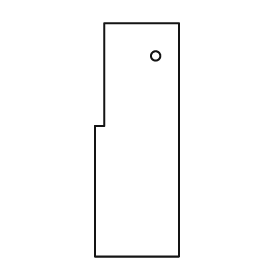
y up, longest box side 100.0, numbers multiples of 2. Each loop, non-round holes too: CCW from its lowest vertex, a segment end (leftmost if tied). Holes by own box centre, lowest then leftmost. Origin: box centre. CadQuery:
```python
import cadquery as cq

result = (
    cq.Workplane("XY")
    .moveTo(-18.0, -50.0)
    .lineTo(18.0, -50.0)
    .lineTo(18.0, 50.0)
    .lineTo(-14.0, 50.0)
    .lineTo(-14.0, 6.0)
    .lineTo(-18.0, 6.0)
    .close()
    .moveTo(8.0, 36.0)
    .circle(2.0)
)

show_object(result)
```